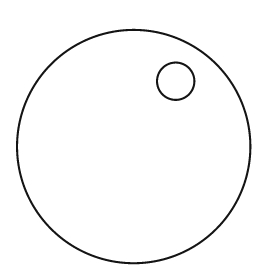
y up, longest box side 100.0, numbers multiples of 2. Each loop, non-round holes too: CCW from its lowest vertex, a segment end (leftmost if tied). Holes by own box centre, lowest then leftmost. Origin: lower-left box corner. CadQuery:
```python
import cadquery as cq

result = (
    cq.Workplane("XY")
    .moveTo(50.0, 50.0)
    .circle(50.0)
    .moveTo(68.0, 78.0)
    .circle(8.0)
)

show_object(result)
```